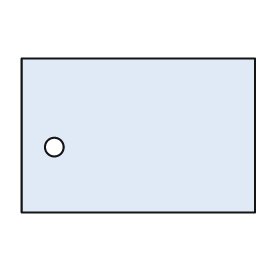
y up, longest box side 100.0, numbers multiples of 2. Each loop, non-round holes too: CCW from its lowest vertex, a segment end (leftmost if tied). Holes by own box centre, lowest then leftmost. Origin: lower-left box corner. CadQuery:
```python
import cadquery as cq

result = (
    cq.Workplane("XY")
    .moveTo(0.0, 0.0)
    .lineTo(100.0, 0.0)
    .lineTo(100.0, 66.0)
    .lineTo(0.0, 66.0)
    .close()
    .moveTo(14.0, 28.0)
    .circle(4.0)
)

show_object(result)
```